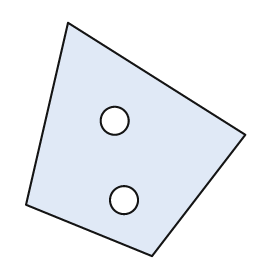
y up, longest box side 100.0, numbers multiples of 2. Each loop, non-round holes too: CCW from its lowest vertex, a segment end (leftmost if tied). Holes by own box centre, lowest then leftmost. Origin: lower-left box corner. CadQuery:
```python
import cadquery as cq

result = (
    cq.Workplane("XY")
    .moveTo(54.0, 0.0)
    .lineTo(94.0, 52.0)
    .lineTo(18.0, 100.0)
    .lineTo(0.0, 22.0)
    .close()
    .moveTo(42.0, 24.0)
    .circle(6.0)
    .moveTo(38.0, 58.0)
    .circle(6.0)
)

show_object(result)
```